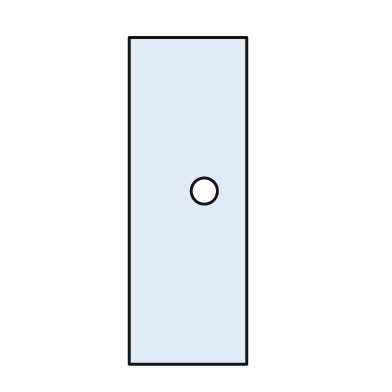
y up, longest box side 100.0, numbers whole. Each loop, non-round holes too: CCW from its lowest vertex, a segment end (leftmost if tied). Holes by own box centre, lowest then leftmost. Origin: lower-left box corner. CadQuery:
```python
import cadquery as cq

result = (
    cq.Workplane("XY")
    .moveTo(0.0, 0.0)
    .lineTo(36.0, 0.0)
    .lineTo(36.0, 100.0)
    .lineTo(0.0, 100.0)
    .close()
    .moveTo(23.0, 53.0)
    .circle(4.0)
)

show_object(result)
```